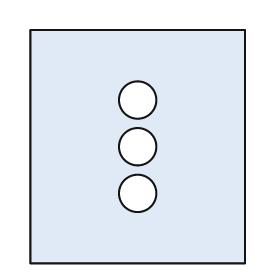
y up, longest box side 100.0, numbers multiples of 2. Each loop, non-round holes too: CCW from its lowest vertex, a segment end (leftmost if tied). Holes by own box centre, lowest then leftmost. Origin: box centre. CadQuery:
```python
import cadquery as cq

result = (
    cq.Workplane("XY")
    .moveTo(-46.0, -50.0)
    .lineTo(46.0, -50.0)
    .lineTo(46.0, 50.0)
    .lineTo(-46.0, 50.0)
    .close()
    .moveTo(0.0, -20.0)
    .circle(8.0)
    .moveTo(0.0, 0.0)
    .circle(8.0)
    .moveTo(0.0, 20.0)
    .circle(8.0)
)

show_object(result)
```